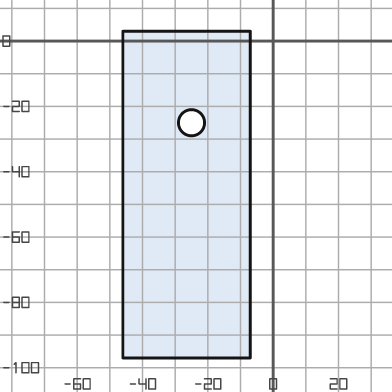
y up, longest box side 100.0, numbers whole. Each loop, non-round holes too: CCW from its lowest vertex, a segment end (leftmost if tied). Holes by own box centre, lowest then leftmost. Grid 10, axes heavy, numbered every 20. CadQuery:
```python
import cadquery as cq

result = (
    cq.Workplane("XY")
    .moveTo(-46.0, -97.0)
    .lineTo(-7.0, -97.0)
    .lineTo(-7.0, 3.0)
    .lineTo(-46.0, 3.0)
    .close()
    .moveTo(-25.0, -25.0)
    .circle(4.0)
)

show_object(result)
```